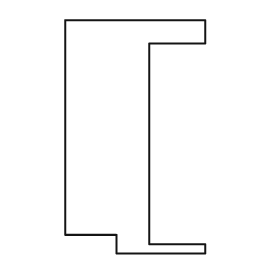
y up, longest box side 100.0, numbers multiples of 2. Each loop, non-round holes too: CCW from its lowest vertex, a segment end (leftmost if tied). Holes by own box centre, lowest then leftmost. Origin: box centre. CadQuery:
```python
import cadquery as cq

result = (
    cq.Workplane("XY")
    .moveTo(-8.0, -50.0)
    .lineTo(30.0, -50.0)
    .lineTo(30.0, -46.0)
    .lineTo(6.0, -46.0)
    .lineTo(6.0, 40.0)
    .lineTo(30.0, 40.0)
    .lineTo(30.0, 50.0)
    .lineTo(-30.0, 50.0)
    .lineTo(-30.0, -42.0)
    .lineTo(-8.0, -42.0)
    .close()
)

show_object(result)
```